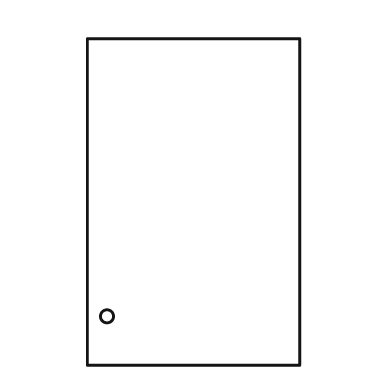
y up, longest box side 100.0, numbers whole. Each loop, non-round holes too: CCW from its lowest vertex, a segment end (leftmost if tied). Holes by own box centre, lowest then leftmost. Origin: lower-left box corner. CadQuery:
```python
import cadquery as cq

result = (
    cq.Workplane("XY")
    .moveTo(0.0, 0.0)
    .lineTo(65.0, 0.0)
    .lineTo(65.0, 100.0)
    .lineTo(0.0, 100.0)
    .close()
    .moveTo(6.0, 15.0)
    .circle(2.0)
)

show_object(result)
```